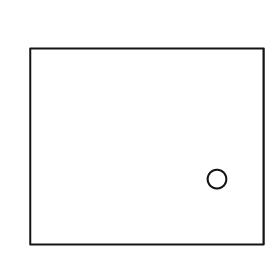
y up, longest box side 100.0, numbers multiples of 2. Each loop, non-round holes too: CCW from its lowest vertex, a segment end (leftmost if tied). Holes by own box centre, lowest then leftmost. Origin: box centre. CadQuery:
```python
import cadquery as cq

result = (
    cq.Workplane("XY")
    .moveTo(-50.0, -42.0)
    .lineTo(50.0, -42.0)
    .lineTo(50.0, 42.0)
    .lineTo(-50.0, 42.0)
    .close()
    .moveTo(30.0, -14.0)
    .circle(4.0)
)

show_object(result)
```